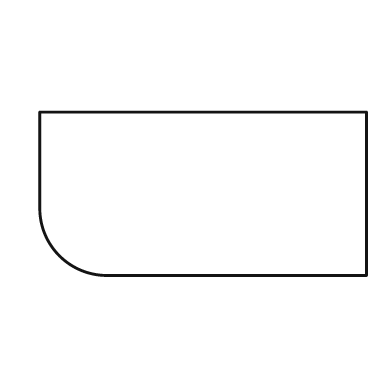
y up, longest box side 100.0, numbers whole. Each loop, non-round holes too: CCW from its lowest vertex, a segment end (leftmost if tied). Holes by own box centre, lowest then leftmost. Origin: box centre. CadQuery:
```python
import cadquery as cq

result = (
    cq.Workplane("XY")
    .moveTo(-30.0, -25.0)
    .lineTo(50.0, -25.0)
    .lineTo(50.0, 25.0)
    .lineTo(-50.0, 25.0)
    .lineTo(-50.0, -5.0)
    .threePointArc((-44.0, -19.0), (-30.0, -25.0))
    .close()
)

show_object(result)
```